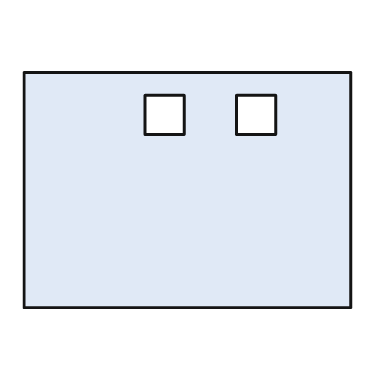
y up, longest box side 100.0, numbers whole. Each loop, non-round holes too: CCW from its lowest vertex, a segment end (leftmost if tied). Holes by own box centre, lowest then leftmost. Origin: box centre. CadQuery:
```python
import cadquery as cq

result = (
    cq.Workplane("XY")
    .moveTo(-50.0, -36.0)
    .lineTo(50.0, -36.0)
    .lineTo(50.0, 36.0)
    .lineTo(-50.0, 36.0)
    .close()
    .moveTo(-13.0, 17.0)
    .lineTo(-1.0, 17.0)
    .lineTo(-1.0, 29.0)
    .lineTo(-13.0, 29.0)
    .close()
    .moveTo(15.0, 17.0)
    .lineTo(27.0, 17.0)
    .lineTo(27.0, 29.0)
    .lineTo(15.0, 29.0)
    .close()
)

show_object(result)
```